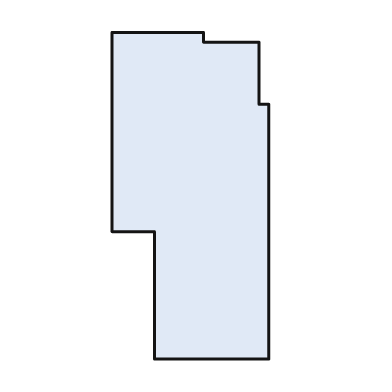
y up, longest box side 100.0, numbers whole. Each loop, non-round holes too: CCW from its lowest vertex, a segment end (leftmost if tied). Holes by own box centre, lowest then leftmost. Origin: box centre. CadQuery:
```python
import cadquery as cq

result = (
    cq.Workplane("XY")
    .moveTo(-11.0, -50.0)
    .lineTo(24.0, -50.0)
    .lineTo(24.0, 28.0)
    .lineTo(21.0, 28.0)
    .lineTo(21.0, 47.0)
    .lineTo(4.0, 47.0)
    .lineTo(4.0, 50.0)
    .lineTo(-24.0, 50.0)
    .lineTo(-24.0, -11.0)
    .lineTo(-11.0, -11.0)
    .close()
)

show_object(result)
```